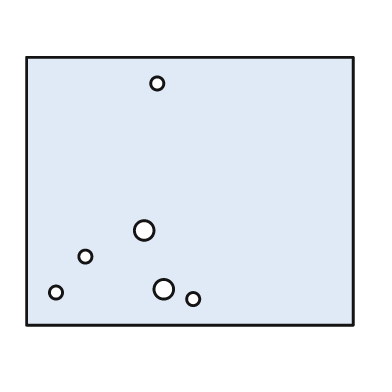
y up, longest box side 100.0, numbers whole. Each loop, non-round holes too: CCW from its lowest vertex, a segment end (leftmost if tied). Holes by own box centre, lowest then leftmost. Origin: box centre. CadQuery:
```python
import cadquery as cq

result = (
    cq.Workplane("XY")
    .moveTo(-50.0, -41.0)
    .lineTo(50.0, -41.0)
    .lineTo(50.0, 41.0)
    .lineTo(-50.0, 41.0)
    .close()
    .moveTo(1.0, -33.0)
    .circle(2.0)
    .moveTo(-41.0, -31.0)
    .circle(2.0)
    .moveTo(-8.0, -30.0)
    .circle(3.0)
    .moveTo(-32.0, -20.0)
    .circle(2.0)
    .moveTo(-14.0, -12.0)
    .circle(3.0)
    .moveTo(-10.0, 33.0)
    .circle(2.0)
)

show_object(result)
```